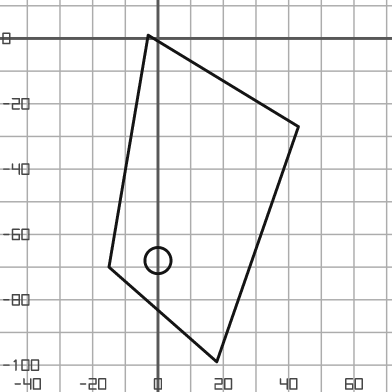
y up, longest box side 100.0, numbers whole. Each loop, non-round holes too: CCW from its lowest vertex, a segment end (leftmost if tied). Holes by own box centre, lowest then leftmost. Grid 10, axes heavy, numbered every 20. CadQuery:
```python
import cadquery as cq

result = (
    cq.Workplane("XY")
    .moveTo(18.0, -99.0)
    .lineTo(43.0, -27.0)
    .lineTo(-3.0, 1.0)
    .lineTo(-15.0, -70.0)
    .close()
    .moveTo(0.0, -68.0)
    .circle(4.0)
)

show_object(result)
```